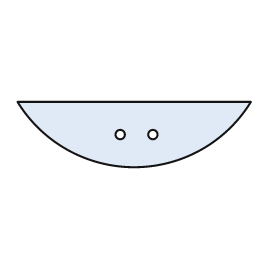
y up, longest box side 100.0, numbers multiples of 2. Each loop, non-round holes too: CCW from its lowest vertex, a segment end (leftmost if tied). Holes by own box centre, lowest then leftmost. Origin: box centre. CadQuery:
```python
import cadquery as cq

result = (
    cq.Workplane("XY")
    .moveTo(-50.0, 14.0)
    .threePointArc((0.0, -14.0), (50.0, 14.0))
    .close()
    .moveTo(-6.0, 0.0)
    .circle(2.0)
    .moveTo(8.0, 0.0)
    .circle(2.0)
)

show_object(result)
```